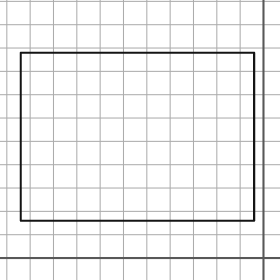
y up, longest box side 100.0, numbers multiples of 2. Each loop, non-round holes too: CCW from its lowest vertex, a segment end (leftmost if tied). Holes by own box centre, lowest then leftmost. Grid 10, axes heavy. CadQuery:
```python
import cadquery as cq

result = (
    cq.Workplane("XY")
    .moveTo(-104.0, 16.0)
    .lineTo(-4.0, 16.0)
    .lineTo(-4.0, 88.0)
    .lineTo(-104.0, 88.0)
    .close()
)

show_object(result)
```